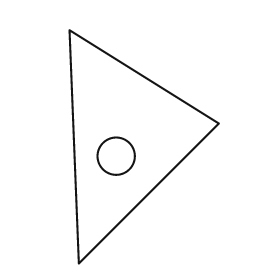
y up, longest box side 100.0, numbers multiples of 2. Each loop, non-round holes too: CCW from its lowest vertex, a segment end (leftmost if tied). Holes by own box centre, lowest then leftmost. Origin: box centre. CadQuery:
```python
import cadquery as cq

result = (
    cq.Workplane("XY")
    .moveTo(-28.0, -50.0)
    .lineTo(32.0, 10.0)
    .lineTo(-32.0, 50.0)
    .close()
    .moveTo(-12.0, -4.0)
    .circle(8.0)
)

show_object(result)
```